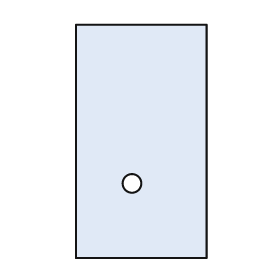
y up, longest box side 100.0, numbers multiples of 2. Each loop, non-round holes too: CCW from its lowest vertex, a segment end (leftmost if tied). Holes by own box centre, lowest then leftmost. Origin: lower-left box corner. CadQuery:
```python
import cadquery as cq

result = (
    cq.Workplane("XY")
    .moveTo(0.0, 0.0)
    .lineTo(56.0, 0.0)
    .lineTo(56.0, 100.0)
    .lineTo(0.0, 100.0)
    .close()
    .moveTo(24.0, 32.0)
    .circle(4.0)
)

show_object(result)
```